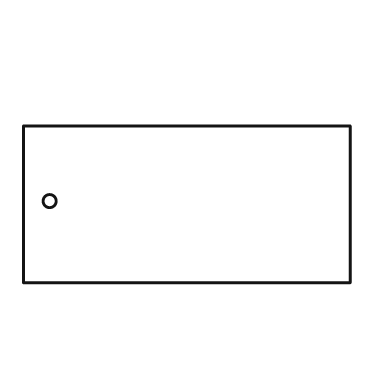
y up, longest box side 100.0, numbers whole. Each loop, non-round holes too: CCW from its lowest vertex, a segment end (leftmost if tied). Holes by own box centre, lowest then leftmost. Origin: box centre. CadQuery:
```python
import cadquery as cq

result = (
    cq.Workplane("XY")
    .moveTo(-50.0, -24.0)
    .lineTo(50.0, -24.0)
    .lineTo(50.0, 24.0)
    .lineTo(-50.0, 24.0)
    .close()
    .moveTo(-42.0, 1.0)
    .circle(2.0)
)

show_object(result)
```